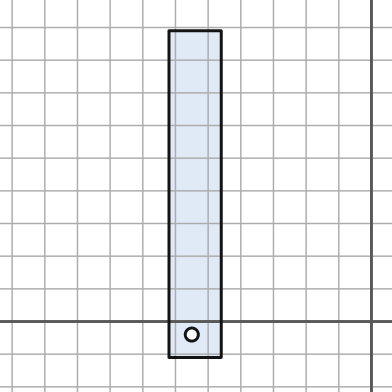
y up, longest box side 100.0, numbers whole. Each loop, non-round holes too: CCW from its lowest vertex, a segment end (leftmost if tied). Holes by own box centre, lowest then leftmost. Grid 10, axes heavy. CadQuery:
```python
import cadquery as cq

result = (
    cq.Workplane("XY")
    .moveTo(-62.0, -11.0)
    .lineTo(-46.0, -11.0)
    .lineTo(-46.0, 89.0)
    .lineTo(-62.0, 89.0)
    .close()
    .moveTo(-55.0, -4.0)
    .circle(2.0)
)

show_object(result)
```